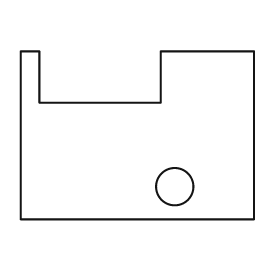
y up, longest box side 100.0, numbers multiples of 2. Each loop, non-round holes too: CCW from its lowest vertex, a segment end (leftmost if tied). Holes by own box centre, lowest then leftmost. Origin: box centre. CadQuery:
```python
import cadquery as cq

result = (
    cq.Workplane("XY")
    .moveTo(-50.0, -36.0)
    .lineTo(50.0, -36.0)
    .lineTo(50.0, 36.0)
    .lineTo(10.0, 36.0)
    .lineTo(10.0, 14.0)
    .lineTo(-42.0, 14.0)
    .lineTo(-42.0, 36.0)
    .lineTo(-50.0, 36.0)
    .close()
    .moveTo(16.0, -22.0)
    .circle(8.0)
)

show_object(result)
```